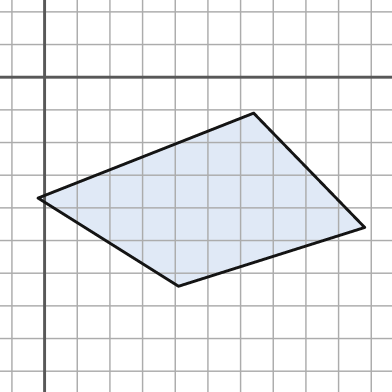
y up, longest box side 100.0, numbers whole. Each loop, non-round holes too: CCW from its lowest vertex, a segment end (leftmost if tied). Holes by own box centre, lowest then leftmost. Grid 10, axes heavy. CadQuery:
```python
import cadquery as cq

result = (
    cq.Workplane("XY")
    .moveTo(41.0, -64.0)
    .lineTo(98.0, -46.0)
    .lineTo(64.0, -11.0)
    .lineTo(-2.0, -37.0)
    .close()
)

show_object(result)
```